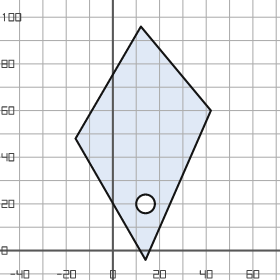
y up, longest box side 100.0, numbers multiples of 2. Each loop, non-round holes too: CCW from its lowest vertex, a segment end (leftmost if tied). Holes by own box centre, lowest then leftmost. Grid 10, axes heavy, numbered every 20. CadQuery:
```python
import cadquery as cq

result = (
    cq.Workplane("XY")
    .moveTo(14.0, -4.0)
    .lineTo(42.0, 60.0)
    .lineTo(12.0, 96.0)
    .lineTo(-16.0, 48.0)
    .close()
    .moveTo(14.0, 20.0)
    .circle(4.0)
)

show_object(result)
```